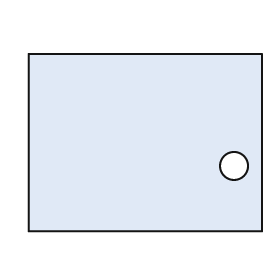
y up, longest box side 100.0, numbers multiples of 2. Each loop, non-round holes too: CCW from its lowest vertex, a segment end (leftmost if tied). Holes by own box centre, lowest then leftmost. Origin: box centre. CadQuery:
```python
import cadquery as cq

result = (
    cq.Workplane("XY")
    .moveTo(-50.0, -38.0)
    .lineTo(50.0, -38.0)
    .lineTo(50.0, 38.0)
    .lineTo(-50.0, 38.0)
    .close()
    .moveTo(38.0, -10.0)
    .circle(6.0)
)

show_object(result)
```